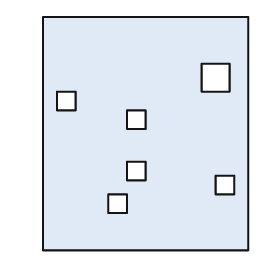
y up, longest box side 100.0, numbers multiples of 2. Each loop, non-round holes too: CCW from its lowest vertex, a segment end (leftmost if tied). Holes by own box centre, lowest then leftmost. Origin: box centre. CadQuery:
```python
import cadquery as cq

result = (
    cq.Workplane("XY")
    .moveTo(-44.0, -50.0)
    .lineTo(44.0, -50.0)
    .lineTo(44.0, 50.0)
    .lineTo(-44.0, 50.0)
    .close()
    .moveTo(-16.0, -34.0)
    .lineTo(-8.0, -34.0)
    .lineTo(-8.0, -26.0)
    .lineTo(-16.0, -26.0)
    .close()
    .moveTo(30.0, -26.0)
    .lineTo(38.0, -26.0)
    .lineTo(38.0, -18.0)
    .lineTo(30.0, -18.0)
    .close()
    .moveTo(-8.0, -20.0)
    .lineTo(0.0, -20.0)
    .lineTo(0.0, -12.0)
    .lineTo(-8.0, -12.0)
    .close()
    .moveTo(-8.0, 2.0)
    .lineTo(0.0, 2.0)
    .lineTo(0.0, 10.0)
    .lineTo(-8.0, 10.0)
    .close()
    .moveTo(-38.0, 10.0)
    .lineTo(-30.0, 10.0)
    .lineTo(-30.0, 18.0)
    .lineTo(-38.0, 18.0)
    .close()
    .moveTo(24.0, 18.0)
    .lineTo(36.0, 18.0)
    .lineTo(36.0, 30.0)
    .lineTo(24.0, 30.0)
    .close()
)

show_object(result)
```